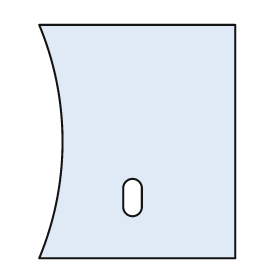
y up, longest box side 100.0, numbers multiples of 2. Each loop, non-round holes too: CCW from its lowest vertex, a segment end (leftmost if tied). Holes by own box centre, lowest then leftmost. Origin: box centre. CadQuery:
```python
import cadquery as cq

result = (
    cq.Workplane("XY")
    .moveTo(-42.0, -50.0)
    .lineTo(42.0, -50.0)
    .lineTo(42.0, 50.0)
    .lineTo(-42.0, 50.0)
    .threePointArc((-32.0, 0.0), (-42.0, -50.0))
    .close()
    .moveTo(-6.0, -28.0)
    .threePointArc((-2.0, -32.0), (2.0, -28.0))
    .lineTo(2.0, -20.0)
    .threePointArc((-2.0, -16.0), (-6.0, -20.0))
    .close()
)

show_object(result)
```